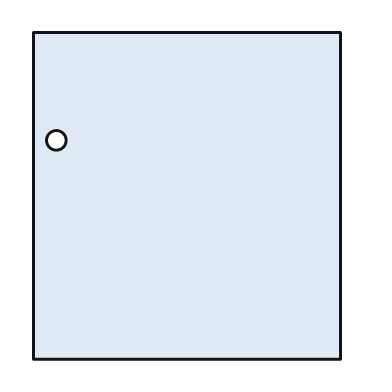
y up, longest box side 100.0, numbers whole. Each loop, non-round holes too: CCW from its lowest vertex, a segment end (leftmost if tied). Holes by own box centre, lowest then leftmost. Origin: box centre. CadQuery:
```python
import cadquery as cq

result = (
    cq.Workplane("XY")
    .moveTo(-47.0, -50.0)
    .lineTo(47.0, -50.0)
    .lineTo(47.0, 50.0)
    .lineTo(-47.0, 50.0)
    .close()
    .moveTo(-40.0, 17.0)
    .circle(3.0)
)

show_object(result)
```